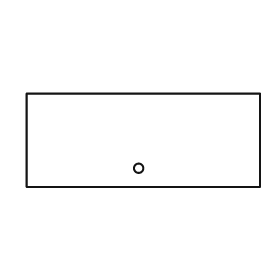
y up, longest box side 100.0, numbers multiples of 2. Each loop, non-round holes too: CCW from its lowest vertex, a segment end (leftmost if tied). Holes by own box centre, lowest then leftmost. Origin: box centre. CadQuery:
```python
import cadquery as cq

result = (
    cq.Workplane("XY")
    .moveTo(-50.0, -20.0)
    .lineTo(50.0, -20.0)
    .lineTo(50.0, 20.0)
    .lineTo(-50.0, 20.0)
    .close()
    .moveTo(-2.0, -12.0)
    .circle(2.0)
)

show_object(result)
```